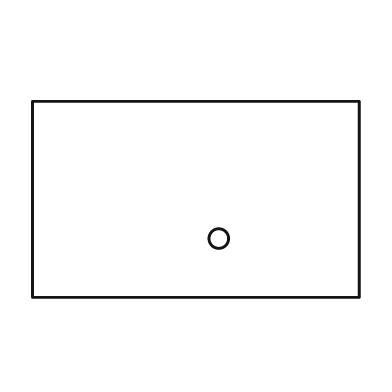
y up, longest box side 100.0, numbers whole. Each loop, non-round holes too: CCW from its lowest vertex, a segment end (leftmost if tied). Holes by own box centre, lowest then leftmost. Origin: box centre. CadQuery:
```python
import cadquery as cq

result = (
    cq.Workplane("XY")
    .moveTo(-50.0, -30.0)
    .lineTo(50.0, -30.0)
    .lineTo(50.0, 30.0)
    .lineTo(-50.0, 30.0)
    .close()
    .moveTo(7.0, -12.0)
    .circle(3.0)
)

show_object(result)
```